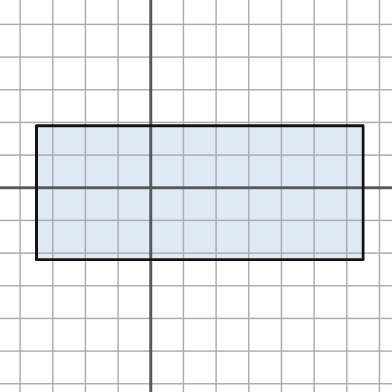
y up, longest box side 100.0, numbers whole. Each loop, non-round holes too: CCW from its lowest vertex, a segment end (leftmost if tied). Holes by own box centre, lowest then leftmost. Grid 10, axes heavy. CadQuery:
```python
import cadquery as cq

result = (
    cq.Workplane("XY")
    .moveTo(-35.0, -22.0)
    .lineTo(65.0, -22.0)
    .lineTo(65.0, 19.0)
    .lineTo(-35.0, 19.0)
    .close()
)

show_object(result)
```